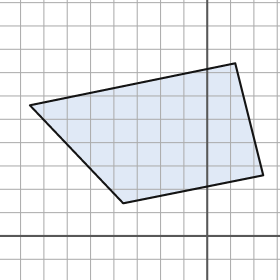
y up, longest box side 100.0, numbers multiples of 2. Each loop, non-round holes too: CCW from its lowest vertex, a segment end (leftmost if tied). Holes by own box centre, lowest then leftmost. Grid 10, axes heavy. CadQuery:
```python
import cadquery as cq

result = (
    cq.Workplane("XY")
    .moveTo(-36.0, 14.0)
    .lineTo(24.0, 26.0)
    .lineTo(12.0, 74.0)
    .lineTo(-76.0, 56.0)
    .close()
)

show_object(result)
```